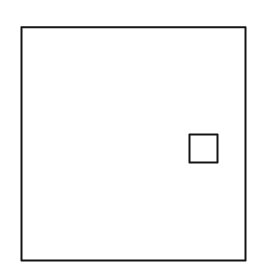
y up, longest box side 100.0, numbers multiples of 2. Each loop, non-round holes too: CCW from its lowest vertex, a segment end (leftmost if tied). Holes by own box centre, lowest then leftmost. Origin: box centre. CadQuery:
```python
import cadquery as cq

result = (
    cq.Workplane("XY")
    .moveTo(-48.0, -50.0)
    .lineTo(48.0, -50.0)
    .lineTo(48.0, 50.0)
    .lineTo(-48.0, 50.0)
    .close()
    .moveTo(24.0, -8.0)
    .lineTo(36.0, -8.0)
    .lineTo(36.0, 4.0)
    .lineTo(24.0, 4.0)
    .close()
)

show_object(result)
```